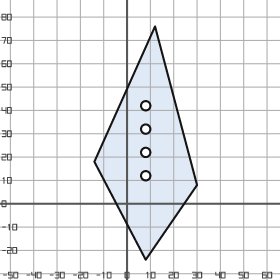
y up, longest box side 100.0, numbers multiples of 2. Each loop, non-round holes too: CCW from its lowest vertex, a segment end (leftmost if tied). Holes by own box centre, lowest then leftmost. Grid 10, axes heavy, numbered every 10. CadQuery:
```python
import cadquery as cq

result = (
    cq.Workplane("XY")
    .moveTo(8.0, -24.0)
    .lineTo(30.0, 8.0)
    .lineTo(12.0, 76.0)
    .lineTo(-14.0, 18.0)
    .close()
    .moveTo(8.0, 12.0)
    .circle(2.0)
    .moveTo(8.0, 22.0)
    .circle(2.0)
    .moveTo(8.0, 32.0)
    .circle(2.0)
    .moveTo(8.0, 42.0)
    .circle(2.0)
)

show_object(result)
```